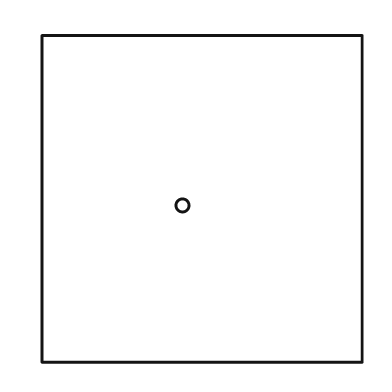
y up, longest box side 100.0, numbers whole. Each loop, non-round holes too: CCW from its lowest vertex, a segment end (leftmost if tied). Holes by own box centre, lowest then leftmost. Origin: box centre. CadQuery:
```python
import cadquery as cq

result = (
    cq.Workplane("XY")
    .moveTo(-49.0, -50.0)
    .lineTo(49.0, -50.0)
    .lineTo(49.0, 50.0)
    .lineTo(-49.0, 50.0)
    .close()
    .moveTo(-6.0, -2.0)
    .circle(2.0)
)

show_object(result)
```